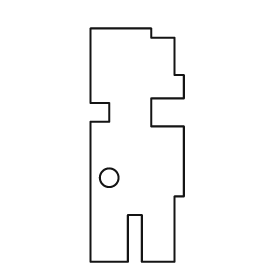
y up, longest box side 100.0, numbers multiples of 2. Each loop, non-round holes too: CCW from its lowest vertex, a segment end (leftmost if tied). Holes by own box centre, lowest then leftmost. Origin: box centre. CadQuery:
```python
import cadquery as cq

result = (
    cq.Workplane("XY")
    .moveTo(-20.0, -50.0)
    .lineTo(-4.0, -50.0)
    .lineTo(-4.0, -30.0)
    .lineTo(2.0, -30.0)
    .lineTo(2.0, -50.0)
    .lineTo(16.0, -50.0)
    .lineTo(16.0, -22.0)
    .lineTo(20.0, -22.0)
    .lineTo(20.0, 8.0)
    .lineTo(6.0, 8.0)
    .lineTo(6.0, 20.0)
    .lineTo(20.0, 20.0)
    .lineTo(20.0, 30.0)
    .lineTo(16.0, 30.0)
    .lineTo(16.0, 46.0)
    .lineTo(6.0, 46.0)
    .lineTo(6.0, 50.0)
    .lineTo(-20.0, 50.0)
    .lineTo(-20.0, 18.0)
    .lineTo(-12.0, 18.0)
    .lineTo(-12.0, 10.0)
    .lineTo(-20.0, 10.0)
    .close()
    .moveTo(-12.0, -14.0)
    .circle(4.0)
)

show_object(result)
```